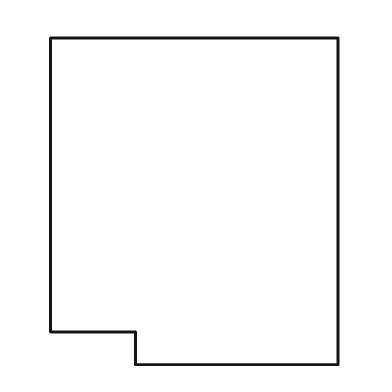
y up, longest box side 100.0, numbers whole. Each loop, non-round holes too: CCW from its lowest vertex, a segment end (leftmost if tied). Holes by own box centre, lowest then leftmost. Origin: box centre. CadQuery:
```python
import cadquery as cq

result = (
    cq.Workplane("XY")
    .moveTo(-18.0, -50.0)
    .lineTo(44.0, -50.0)
    .lineTo(44.0, 50.0)
    .lineTo(-44.0, 50.0)
    .lineTo(-44.0, -40.0)
    .lineTo(-18.0, -40.0)
    .close()
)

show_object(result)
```